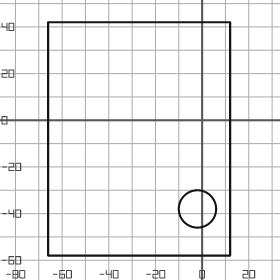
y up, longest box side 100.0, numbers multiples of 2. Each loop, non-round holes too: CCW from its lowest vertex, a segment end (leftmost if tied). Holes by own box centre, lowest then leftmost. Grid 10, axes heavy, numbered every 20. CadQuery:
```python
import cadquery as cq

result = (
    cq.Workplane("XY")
    .moveTo(-66.0, -58.0)
    .lineTo(12.0, -58.0)
    .lineTo(12.0, 42.0)
    .lineTo(-66.0, 42.0)
    .close()
    .moveTo(-2.0, -38.0)
    .circle(8.0)
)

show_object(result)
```